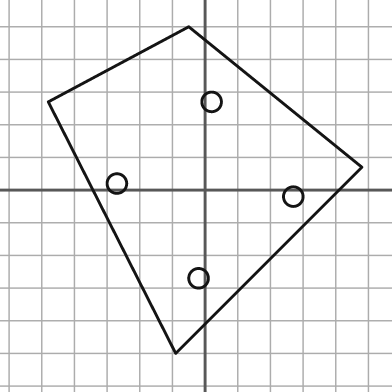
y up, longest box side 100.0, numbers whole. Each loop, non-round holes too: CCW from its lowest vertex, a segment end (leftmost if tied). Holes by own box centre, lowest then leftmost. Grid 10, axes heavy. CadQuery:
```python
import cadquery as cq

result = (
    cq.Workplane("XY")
    .moveTo(-9.0, -50.0)
    .lineTo(48.0, 7.0)
    .lineTo(-5.0, 50.0)
    .lineTo(-48.0, 27.0)
    .close()
    .moveTo(-2.0, -27.0)
    .circle(3.0)
    .moveTo(27.0, -2.0)
    .circle(3.0)
    .moveTo(-27.0, 2.0)
    .circle(3.0)
    .moveTo(2.0, 27.0)
    .circle(3.0)
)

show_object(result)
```